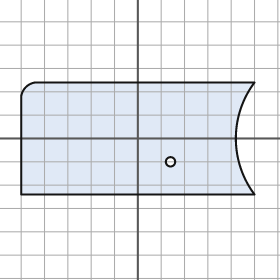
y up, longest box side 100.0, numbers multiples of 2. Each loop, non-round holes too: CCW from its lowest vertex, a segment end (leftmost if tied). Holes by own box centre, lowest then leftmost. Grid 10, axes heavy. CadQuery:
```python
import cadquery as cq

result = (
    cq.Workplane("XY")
    .moveTo(-50.0, -24.0)
    .lineTo(50.0, -24.0)
    .threePointArc((42.0, 0.0), (50.0, 24.0))
    .lineTo(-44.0, 24.0)
    .threePointArc((-48.0, 22.0), (-50.0, 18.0))
    .close()
    .moveTo(14.0, -10.0)
    .circle(2.0)
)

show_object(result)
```